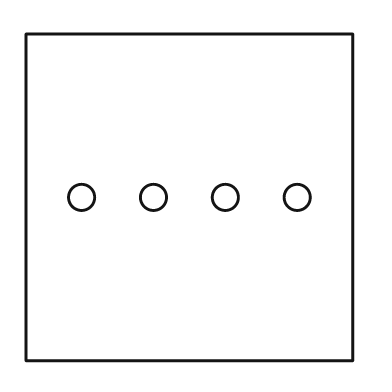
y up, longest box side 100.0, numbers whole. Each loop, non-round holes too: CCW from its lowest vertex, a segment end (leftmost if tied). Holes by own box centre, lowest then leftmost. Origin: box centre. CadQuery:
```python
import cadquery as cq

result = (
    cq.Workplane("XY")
    .moveTo(-50.0, -50.0)
    .lineTo(50.0, -50.0)
    .lineTo(50.0, 50.0)
    .lineTo(-50.0, 50.0)
    .close()
    .moveTo(-33.0, 0.0)
    .circle(4.0)
    .moveTo(-11.0, 0.0)
    .circle(4.0)
    .moveTo(11.0, 0.0)
    .circle(4.0)
    .moveTo(33.0, 0.0)
    .circle(4.0)
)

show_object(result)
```